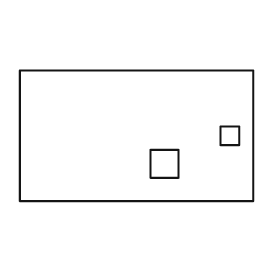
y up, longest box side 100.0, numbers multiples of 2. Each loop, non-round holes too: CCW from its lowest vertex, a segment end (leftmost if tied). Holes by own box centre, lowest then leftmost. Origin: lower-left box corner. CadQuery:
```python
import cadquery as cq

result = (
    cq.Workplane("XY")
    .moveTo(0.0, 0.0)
    .lineTo(100.0, 0.0)
    .lineTo(100.0, 56.0)
    .lineTo(0.0, 56.0)
    .close()
    .moveTo(56.0, 10.0)
    .lineTo(68.0, 10.0)
    .lineTo(68.0, 22.0)
    .lineTo(56.0, 22.0)
    .close()
    .moveTo(86.0, 24.0)
    .lineTo(94.0, 24.0)
    .lineTo(94.0, 32.0)
    .lineTo(86.0, 32.0)
    .close()
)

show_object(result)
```